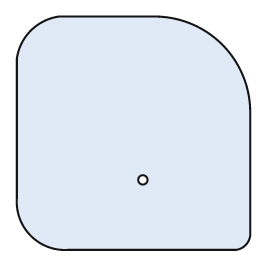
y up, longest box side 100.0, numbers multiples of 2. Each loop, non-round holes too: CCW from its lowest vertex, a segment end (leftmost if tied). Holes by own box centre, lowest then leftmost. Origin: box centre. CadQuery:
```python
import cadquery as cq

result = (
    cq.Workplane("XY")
    .moveTo(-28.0, -50.0)
    .lineTo(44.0, -50.0)
    .threePointArc((48.0, -48.0), (50.0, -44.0))
    .lineTo(50.0, 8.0)
    .threePointArc((38.0, 38.0), (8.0, 50.0))
    .lineTo(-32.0, 50.0)
    .threePointArc((-44.0, 44.0), (-50.0, 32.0))
    .lineTo(-50.0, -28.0)
    .threePointArc((-44.0, -44.0), (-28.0, -50.0))
    .close()
    .moveTo(4.0, -20.0)
    .circle(2.0)
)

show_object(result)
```